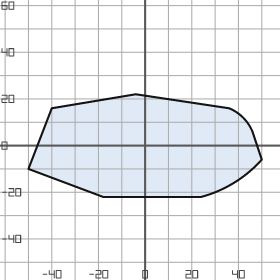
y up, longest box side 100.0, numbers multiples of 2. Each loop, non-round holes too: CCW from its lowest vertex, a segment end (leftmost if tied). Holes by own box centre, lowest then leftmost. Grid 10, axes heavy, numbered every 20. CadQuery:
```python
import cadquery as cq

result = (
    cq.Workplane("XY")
    .moveTo(-18.0, -22.0)
    .lineTo(24.0, -22.0)
    .threePointArc((38.0, -16.0), (50.0, -6.0))
    .lineTo(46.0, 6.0)
    .threePointArc((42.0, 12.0), (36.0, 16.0))
    .lineTo(-4.0, 22.0)
    .lineTo(-40.0, 16.0)
    .lineTo(-50.0, -10.0)
    .close()
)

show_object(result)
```